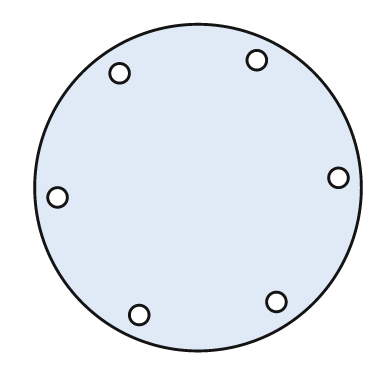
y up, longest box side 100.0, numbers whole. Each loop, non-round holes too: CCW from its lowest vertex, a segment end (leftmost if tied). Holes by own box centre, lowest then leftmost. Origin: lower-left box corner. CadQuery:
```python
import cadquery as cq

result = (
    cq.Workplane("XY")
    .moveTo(50.0, 50.0)
    .circle(50.0)
    .moveTo(32.0, 11.0)
    .circle(3.0)
    .moveTo(74.0, 15.0)
    .circle(3.0)
    .moveTo(7.0, 47.0)
    .circle(3.0)
    .moveTo(93.0, 53.0)
    .circle(3.0)
    .moveTo(26.0, 85.0)
    .circle(3.0)
    .moveTo(68.0, 89.0)
    .circle(3.0)
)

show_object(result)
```